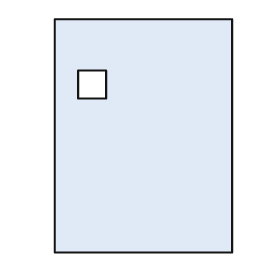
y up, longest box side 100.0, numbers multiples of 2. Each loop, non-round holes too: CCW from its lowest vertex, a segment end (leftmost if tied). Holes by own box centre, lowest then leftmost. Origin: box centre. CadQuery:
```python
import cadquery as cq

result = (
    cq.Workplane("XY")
    .moveTo(-38.0, -50.0)
    .lineTo(38.0, -50.0)
    .lineTo(38.0, 50.0)
    .lineTo(-38.0, 50.0)
    .close()
    .moveTo(-28.0, 16.0)
    .lineTo(-16.0, 16.0)
    .lineTo(-16.0, 28.0)
    .lineTo(-28.0, 28.0)
    .close()
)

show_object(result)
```